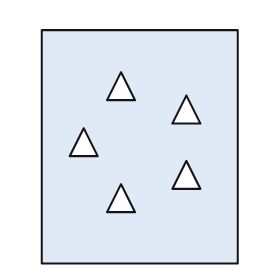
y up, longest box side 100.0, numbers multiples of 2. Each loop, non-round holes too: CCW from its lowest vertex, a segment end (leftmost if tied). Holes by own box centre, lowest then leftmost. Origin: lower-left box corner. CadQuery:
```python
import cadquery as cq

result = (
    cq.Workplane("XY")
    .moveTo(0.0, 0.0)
    .lineTo(84.0, 0.0)
    .lineTo(84.0, 100.0)
    .lineTo(0.0, 100.0)
    .close()
    .moveTo(28.0, 22.0)
    .lineTo(40.0, 22.0)
    .lineTo(34.0, 34.0)
    .close()
    .moveTo(56.0, 32.0)
    .lineTo(68.0, 32.0)
    .lineTo(62.0, 44.0)
    .close()
    .moveTo(12.0, 46.0)
    .lineTo(24.0, 46.0)
    .lineTo(18.0, 58.0)
    .close()
    .moveTo(56.0, 60.0)
    .lineTo(68.0, 60.0)
    .lineTo(62.0, 72.0)
    .close()
    .moveTo(28.0, 70.0)
    .lineTo(40.0, 70.0)
    .lineTo(34.0, 82.0)
    .close()
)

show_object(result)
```